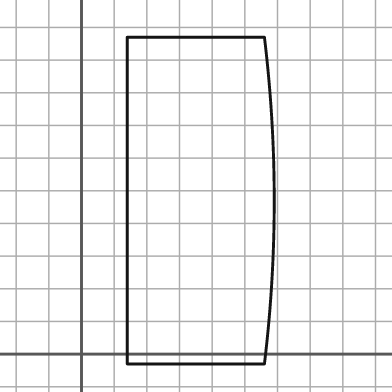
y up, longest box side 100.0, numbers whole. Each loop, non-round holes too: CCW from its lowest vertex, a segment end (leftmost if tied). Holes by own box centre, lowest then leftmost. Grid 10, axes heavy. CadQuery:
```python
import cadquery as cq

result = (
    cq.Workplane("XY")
    .moveTo(14.0, -3.0)
    .lineTo(56.0, -3.0)
    .threePointArc((59.0, 47.0), (56.0, 97.0))
    .lineTo(14.0, 97.0)
    .close()
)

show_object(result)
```